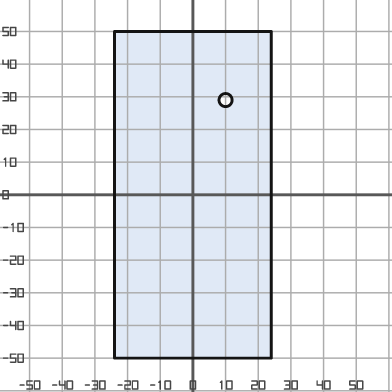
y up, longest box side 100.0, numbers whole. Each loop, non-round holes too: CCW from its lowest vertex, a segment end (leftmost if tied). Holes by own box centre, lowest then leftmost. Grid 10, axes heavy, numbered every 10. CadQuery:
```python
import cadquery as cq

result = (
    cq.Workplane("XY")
    .moveTo(-24.0, -50.0)
    .lineTo(24.0, -50.0)
    .lineTo(24.0, 50.0)
    .lineTo(-24.0, 50.0)
    .close()
    .moveTo(10.0, 29.0)
    .circle(2.0)
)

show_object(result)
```